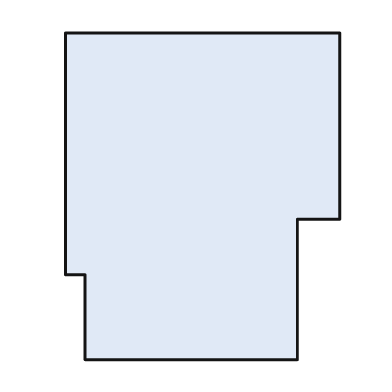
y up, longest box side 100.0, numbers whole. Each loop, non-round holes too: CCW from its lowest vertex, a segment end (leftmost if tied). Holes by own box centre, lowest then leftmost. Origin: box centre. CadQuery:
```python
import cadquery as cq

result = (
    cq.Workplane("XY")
    .moveTo(-36.0, -50.0)
    .lineTo(29.0, -50.0)
    .lineTo(29.0, -7.0)
    .lineTo(42.0, -7.0)
    .lineTo(42.0, 50.0)
    .lineTo(-42.0, 50.0)
    .lineTo(-42.0, -24.0)
    .lineTo(-36.0, -24.0)
    .close()
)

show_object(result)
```